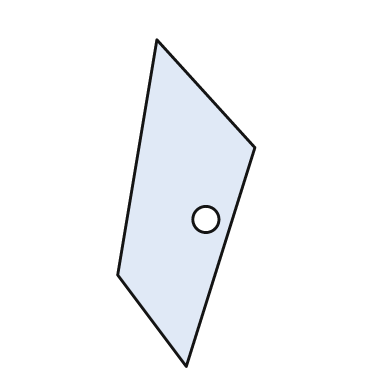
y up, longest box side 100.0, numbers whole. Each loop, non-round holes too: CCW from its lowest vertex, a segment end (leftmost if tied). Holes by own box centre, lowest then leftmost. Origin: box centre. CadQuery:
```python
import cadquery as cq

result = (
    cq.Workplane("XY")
    .moveTo(0.0, -50.0)
    .lineTo(21.0, 17.0)
    .lineTo(-9.0, 50.0)
    .lineTo(-21.0, -22.0)
    .close()
    .moveTo(6.0, -5.0)
    .circle(4.0)
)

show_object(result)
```